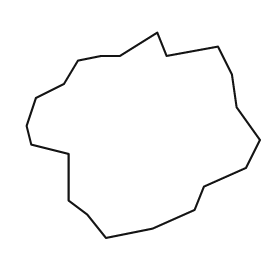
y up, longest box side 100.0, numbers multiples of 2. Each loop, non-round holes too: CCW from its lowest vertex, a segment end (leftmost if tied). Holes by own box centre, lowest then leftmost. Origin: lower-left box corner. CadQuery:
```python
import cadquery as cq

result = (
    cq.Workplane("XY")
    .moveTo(34.0, 0.0)
    .lineTo(54.0, 4.0)
    .lineTo(72.0, 12.0)
    .lineTo(76.0, 22.0)
    .lineTo(94.0, 30.0)
    .lineTo(100.0, 42.0)
    .lineTo(90.0, 56.0)
    .lineTo(88.0, 70.0)
    .lineTo(82.0, 82.0)
    .lineTo(60.0, 78.0)
    .lineTo(56.0, 88.0)
    .lineTo(40.0, 78.0)
    .lineTo(32.0, 78.0)
    .lineTo(22.0, 76.0)
    .lineTo(16.0, 66.0)
    .lineTo(4.0, 60.0)
    .lineTo(0.0, 48.0)
    .lineTo(2.0, 40.0)
    .lineTo(18.0, 36.0)
    .lineTo(18.0, 16.0)
    .lineTo(26.0, 10.0)
    .close()
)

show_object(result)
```